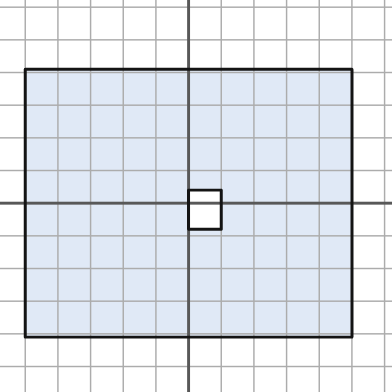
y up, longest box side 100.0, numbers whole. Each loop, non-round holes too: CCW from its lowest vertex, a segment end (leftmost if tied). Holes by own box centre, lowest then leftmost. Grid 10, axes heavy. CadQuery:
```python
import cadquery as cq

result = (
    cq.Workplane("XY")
    .moveTo(-50.0, -41.0)
    .lineTo(50.0, -41.0)
    .lineTo(50.0, 41.0)
    .lineTo(-50.0, 41.0)
    .close()
    .moveTo(0.0, -8.0)
    .lineTo(10.0, -8.0)
    .lineTo(10.0, 4.0)
    .lineTo(0.0, 4.0)
    .close()
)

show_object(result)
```